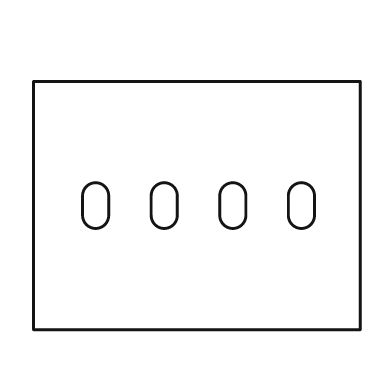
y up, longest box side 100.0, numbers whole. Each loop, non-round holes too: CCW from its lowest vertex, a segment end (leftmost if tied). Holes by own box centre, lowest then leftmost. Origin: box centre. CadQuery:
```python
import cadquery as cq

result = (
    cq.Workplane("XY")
    .moveTo(-50.0, -38.0)
    .lineTo(50.0, -38.0)
    .lineTo(50.0, 38.0)
    .lineTo(-50.0, 38.0)
    .close()
    .moveTo(-35.0, -3.0)
    .threePointArc((-31.0, -7.0), (-27.0, -3.0))
    .lineTo(-27.0, 3.0)
    .threePointArc((-31.0, 7.0), (-35.0, 3.0))
    .close()
    .moveTo(-14.0, -3.0)
    .threePointArc((-10.0, -7.0), (-6.0, -3.0))
    .lineTo(-6.0, 3.0)
    .threePointArc((-10.0, 7.0), (-14.0, 3.0))
    .close()
    .moveTo(7.0, -3.0)
    .threePointArc((11.0, -7.0), (15.0, -3.0))
    .lineTo(15.0, 3.0)
    .threePointArc((11.0, 7.0), (7.0, 3.0))
    .close()
    .moveTo(28.0, -3.0)
    .threePointArc((32.0, -7.0), (36.0, -3.0))
    .lineTo(36.0, 3.0)
    .threePointArc((32.0, 7.0), (28.0, 3.0))
    .close()
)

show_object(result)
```